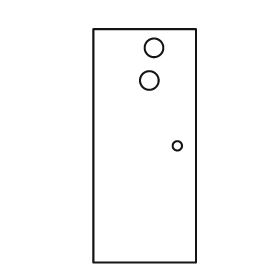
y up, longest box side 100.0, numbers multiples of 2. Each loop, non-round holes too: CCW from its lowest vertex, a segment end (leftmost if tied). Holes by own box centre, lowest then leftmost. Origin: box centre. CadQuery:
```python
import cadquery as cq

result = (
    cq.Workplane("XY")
    .moveTo(-22.0, -50.0)
    .lineTo(22.0, -50.0)
    .lineTo(22.0, 50.0)
    .lineTo(-22.0, 50.0)
    .close()
    .moveTo(14.0, 0.0)
    .circle(2.0)
    .moveTo(2.0, 28.0)
    .circle(4.0)
    .moveTo(4.0, 42.0)
    .circle(4.0)
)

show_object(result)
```